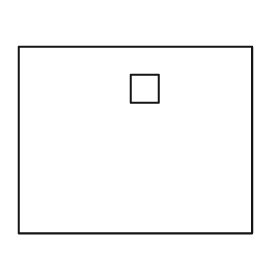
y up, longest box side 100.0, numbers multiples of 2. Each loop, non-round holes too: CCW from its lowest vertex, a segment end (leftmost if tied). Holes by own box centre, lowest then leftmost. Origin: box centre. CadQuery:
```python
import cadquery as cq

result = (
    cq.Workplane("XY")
    .moveTo(-50.0, -40.0)
    .lineTo(50.0, -40.0)
    .lineTo(50.0, 40.0)
    .lineTo(-50.0, 40.0)
    .close()
    .moveTo(-2.0, 16.0)
    .lineTo(10.0, 16.0)
    .lineTo(10.0, 28.0)
    .lineTo(-2.0, 28.0)
    .close()
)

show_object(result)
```